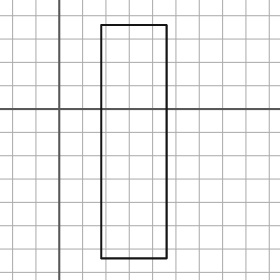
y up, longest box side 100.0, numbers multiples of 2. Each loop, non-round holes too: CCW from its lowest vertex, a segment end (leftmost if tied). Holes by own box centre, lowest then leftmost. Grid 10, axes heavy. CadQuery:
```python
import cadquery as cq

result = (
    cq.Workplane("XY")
    .moveTo(18.0, -64.0)
    .lineTo(46.0, -64.0)
    .lineTo(46.0, 36.0)
    .lineTo(18.0, 36.0)
    .close()
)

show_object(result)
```